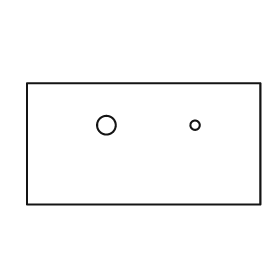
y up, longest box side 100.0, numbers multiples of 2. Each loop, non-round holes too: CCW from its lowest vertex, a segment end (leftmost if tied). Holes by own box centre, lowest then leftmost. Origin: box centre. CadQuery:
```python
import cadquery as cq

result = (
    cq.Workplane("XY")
    .moveTo(-50.0, -26.0)
    .lineTo(50.0, -26.0)
    .lineTo(50.0, 26.0)
    .lineTo(-50.0, 26.0)
    .close()
    .moveTo(-16.0, 8.0)
    .circle(4.0)
    .moveTo(22.0, 8.0)
    .circle(2.0)
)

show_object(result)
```